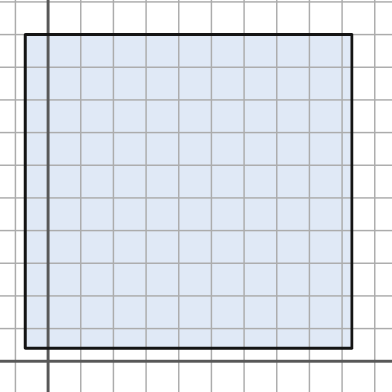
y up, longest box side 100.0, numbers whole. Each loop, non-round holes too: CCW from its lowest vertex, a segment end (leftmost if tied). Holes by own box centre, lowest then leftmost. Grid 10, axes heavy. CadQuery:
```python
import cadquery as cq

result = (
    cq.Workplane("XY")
    .moveTo(-7.0, 4.0)
    .lineTo(93.0, 4.0)
    .lineTo(93.0, 100.0)
    .lineTo(-7.0, 100.0)
    .close()
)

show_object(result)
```